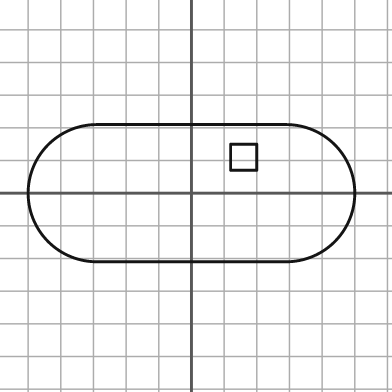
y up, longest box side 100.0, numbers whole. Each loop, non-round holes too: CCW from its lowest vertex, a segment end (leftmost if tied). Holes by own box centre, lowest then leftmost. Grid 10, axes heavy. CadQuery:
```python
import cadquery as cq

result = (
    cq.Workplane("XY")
    .moveTo(-29.0, -21.0)
    .lineTo(29.0, -21.0)
    .threePointArc((50.0, 0.0), (29.0, 21.0))
    .lineTo(-29.0, 21.0)
    .threePointArc((-50.0, 0.0), (-29.0, -21.0))
    .close()
    .moveTo(12.0, 7.0)
    .lineTo(20.0, 7.0)
    .lineTo(20.0, 15.0)
    .lineTo(12.0, 15.0)
    .close()
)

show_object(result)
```